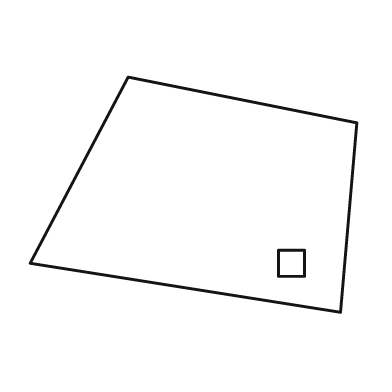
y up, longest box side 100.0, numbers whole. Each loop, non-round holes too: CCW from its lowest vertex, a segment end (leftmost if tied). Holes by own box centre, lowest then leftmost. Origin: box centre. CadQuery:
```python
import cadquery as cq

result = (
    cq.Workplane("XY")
    .moveTo(45.0, -36.0)
    .lineTo(50.0, 22.0)
    .lineTo(-20.0, 36.0)
    .lineTo(-50.0, -21.0)
    .close()
    .moveTo(26.0, -25.0)
    .lineTo(34.0, -25.0)
    .lineTo(34.0, -17.0)
    .lineTo(26.0, -17.0)
    .close()
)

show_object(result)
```